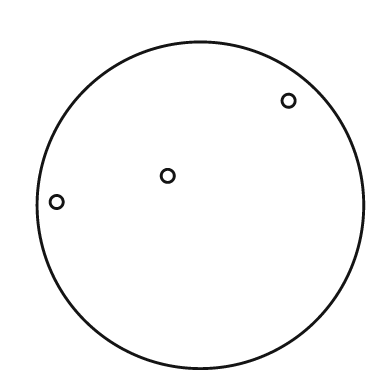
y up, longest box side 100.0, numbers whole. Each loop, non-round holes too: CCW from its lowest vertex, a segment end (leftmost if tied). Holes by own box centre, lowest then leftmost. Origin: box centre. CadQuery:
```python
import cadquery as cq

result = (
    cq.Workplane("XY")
    .moveTo(0.0, 0.0)
    .circle(50.0)
    .moveTo(-44.0, 1.0)
    .circle(2.0)
    .moveTo(-10.0, 9.0)
    .circle(2.0)
    .moveTo(27.0, 32.0)
    .circle(2.0)
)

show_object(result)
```